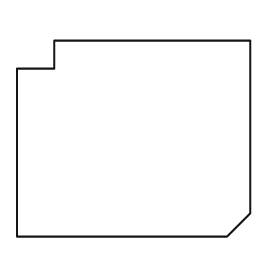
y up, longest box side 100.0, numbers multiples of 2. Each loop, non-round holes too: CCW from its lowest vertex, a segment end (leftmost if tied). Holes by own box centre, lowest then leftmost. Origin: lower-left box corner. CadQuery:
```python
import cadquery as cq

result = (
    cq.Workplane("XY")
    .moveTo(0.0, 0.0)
    .lineTo(90.0, 0.0)
    .lineTo(100.0, 10.0)
    .lineTo(100.0, 84.0)
    .lineTo(16.0, 84.0)
    .lineTo(16.0, 72.0)
    .lineTo(0.0, 72.0)
    .close()
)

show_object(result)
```